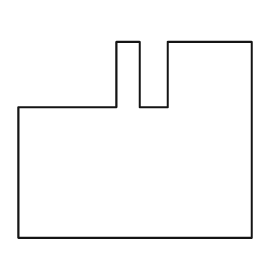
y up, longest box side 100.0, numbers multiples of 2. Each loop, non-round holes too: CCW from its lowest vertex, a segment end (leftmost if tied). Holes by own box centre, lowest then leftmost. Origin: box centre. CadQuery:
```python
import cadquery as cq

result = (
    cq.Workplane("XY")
    .moveTo(-50.0, -42.0)
    .lineTo(50.0, -42.0)
    .lineTo(50.0, 42.0)
    .lineTo(14.0, 42.0)
    .lineTo(14.0, 14.0)
    .lineTo(2.0, 14.0)
    .lineTo(2.0, 42.0)
    .lineTo(-8.0, 42.0)
    .lineTo(-8.0, 14.0)
    .lineTo(-50.0, 14.0)
    .close()
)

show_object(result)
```